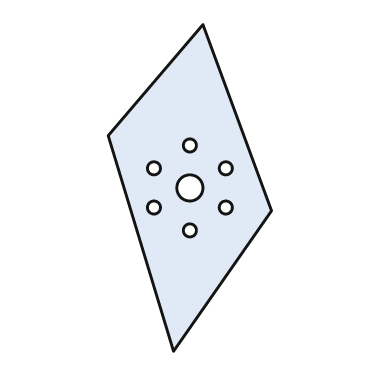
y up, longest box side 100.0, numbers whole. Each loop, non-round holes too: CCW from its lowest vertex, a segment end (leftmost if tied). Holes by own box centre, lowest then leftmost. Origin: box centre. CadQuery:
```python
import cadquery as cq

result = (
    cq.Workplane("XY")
    .moveTo(-5.0, -50.0)
    .lineTo(25.0, -7.0)
    .lineTo(4.0, 50.0)
    .lineTo(-25.0, 16.0)
    .close()
    .moveTo(0.0, -13.0)
    .circle(2.0)
    .moveTo(-11.0, -6.0)
    .circle(2.0)
    .moveTo(11.0, -6.0)
    .circle(2.0)
    .moveTo(0.0, 0.0)
    .circle(4.0)
    .moveTo(-11.0, 6.0)
    .circle(2.0)
    .moveTo(11.0, 6.0)
    .circle(2.0)
    .moveTo(0.0, 13.0)
    .circle(2.0)
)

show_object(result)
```